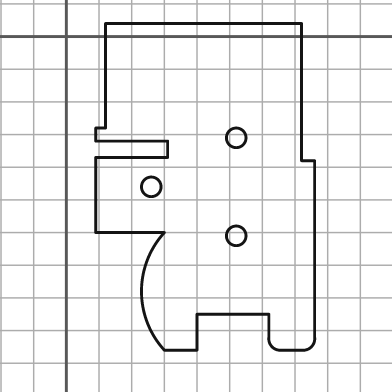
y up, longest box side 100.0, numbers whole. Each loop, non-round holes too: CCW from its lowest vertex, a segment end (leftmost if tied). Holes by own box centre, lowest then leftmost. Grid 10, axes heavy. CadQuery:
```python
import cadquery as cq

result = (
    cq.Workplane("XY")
    .moveTo(30.0, -96.0)
    .lineTo(40.0, -96.0)
    .lineTo(40.0, -85.0)
    .lineTo(62.0, -85.0)
    .lineTo(62.0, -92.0)
    .threePointArc((63.0, -95.0), (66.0, -96.0))
    .lineTo(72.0, -96.0)
    .threePointArc((75.0, -95.0), (76.0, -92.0))
    .lineTo(76.0, -38.0)
    .lineTo(72.0, -38.0)
    .lineTo(72.0, 4.0)
    .lineTo(12.0, 4.0)
    .lineTo(12.0, -28.0)
    .lineTo(9.0, -28.0)
    .lineTo(9.0, -32.0)
    .lineTo(31.0, -32.0)
    .lineTo(31.0, -37.0)
    .lineTo(9.0, -37.0)
    .lineTo(9.0, -60.0)
    .lineTo(30.0, -60.0)
    .threePointArc((23.0, -78.0), (30.0, -96.0))
    .close()
    .moveTo(52.0, -61.0)
    .circle(3.0)
    .moveTo(26.0, -46.0)
    .circle(3.0)
    .moveTo(52.0, -31.0)
    .circle(3.0)
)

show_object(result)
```